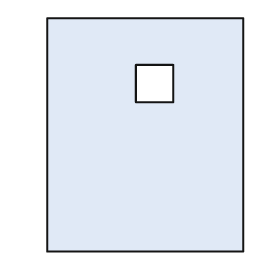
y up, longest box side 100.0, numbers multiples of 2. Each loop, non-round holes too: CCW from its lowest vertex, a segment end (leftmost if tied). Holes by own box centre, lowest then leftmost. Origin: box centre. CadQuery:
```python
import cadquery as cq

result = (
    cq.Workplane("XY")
    .moveTo(-42.0, -50.0)
    .lineTo(42.0, -50.0)
    .lineTo(42.0, 50.0)
    .lineTo(-42.0, 50.0)
    .close()
    .moveTo(-4.0, 14.0)
    .lineTo(12.0, 14.0)
    .lineTo(12.0, 30.0)
    .lineTo(-4.0, 30.0)
    .close()
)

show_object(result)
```